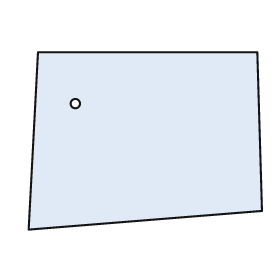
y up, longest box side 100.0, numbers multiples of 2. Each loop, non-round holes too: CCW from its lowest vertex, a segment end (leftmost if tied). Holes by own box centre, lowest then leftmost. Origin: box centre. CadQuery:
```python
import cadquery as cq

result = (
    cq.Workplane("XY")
    .moveTo(-50.0, -38.0)
    .lineTo(50.0, -30.0)
    .lineTo(48.0, 38.0)
    .lineTo(-46.0, 38.0)
    .close()
    .moveTo(-30.0, 16.0)
    .circle(2.0)
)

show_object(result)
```